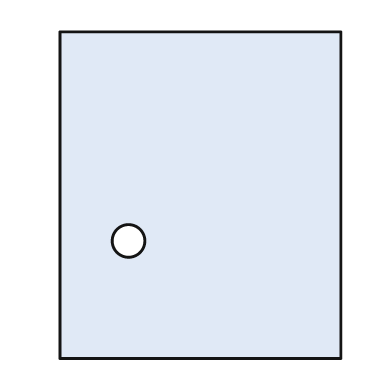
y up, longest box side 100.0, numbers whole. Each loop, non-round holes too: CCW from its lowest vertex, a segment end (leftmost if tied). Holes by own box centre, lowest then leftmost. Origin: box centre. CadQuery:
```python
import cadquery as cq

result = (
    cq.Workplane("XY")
    .moveTo(-43.0, -50.0)
    .lineTo(43.0, -50.0)
    .lineTo(43.0, 50.0)
    .lineTo(-43.0, 50.0)
    .close()
    .moveTo(-22.0, -14.0)
    .circle(5.0)
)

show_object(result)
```